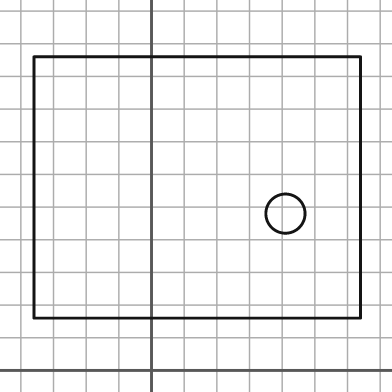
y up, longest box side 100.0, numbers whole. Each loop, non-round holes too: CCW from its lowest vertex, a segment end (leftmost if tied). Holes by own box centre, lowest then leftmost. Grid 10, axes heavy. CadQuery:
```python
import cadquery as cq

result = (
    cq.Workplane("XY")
    .moveTo(-36.0, 16.0)
    .lineTo(64.0, 16.0)
    .lineTo(64.0, 96.0)
    .lineTo(-36.0, 96.0)
    .close()
    .moveTo(41.0, 48.0)
    .circle(6.0)
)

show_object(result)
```